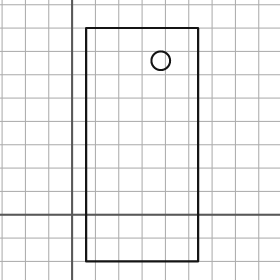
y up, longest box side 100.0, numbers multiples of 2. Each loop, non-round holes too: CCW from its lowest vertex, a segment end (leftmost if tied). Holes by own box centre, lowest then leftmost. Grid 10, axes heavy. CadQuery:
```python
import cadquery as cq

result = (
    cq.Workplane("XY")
    .moveTo(6.0, -20.0)
    .lineTo(54.0, -20.0)
    .lineTo(54.0, 80.0)
    .lineTo(6.0, 80.0)
    .close()
    .moveTo(38.0, 66.0)
    .circle(4.0)
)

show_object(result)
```